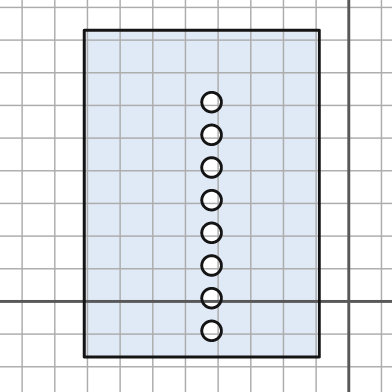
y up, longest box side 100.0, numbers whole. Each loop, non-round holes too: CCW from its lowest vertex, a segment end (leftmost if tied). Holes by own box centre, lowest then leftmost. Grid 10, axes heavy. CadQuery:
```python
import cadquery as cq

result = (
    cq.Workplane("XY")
    .moveTo(-81.0, -17.0)
    .lineTo(-9.0, -17.0)
    .lineTo(-9.0, 83.0)
    .lineTo(-81.0, 83.0)
    .close()
    .moveTo(-42.0, -9.0)
    .circle(3.0)
    .moveTo(-42.0, 1.0)
    .circle(3.0)
    .moveTo(-42.0, 11.0)
    .circle(3.0)
    .moveTo(-42.0, 21.0)
    .circle(3.0)
    .moveTo(-42.0, 31.0)
    .circle(3.0)
    .moveTo(-42.0, 41.0)
    .circle(3.0)
    .moveTo(-42.0, 51.0)
    .circle(3.0)
    .moveTo(-42.0, 61.0)
    .circle(3.0)
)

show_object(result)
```